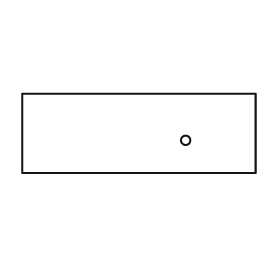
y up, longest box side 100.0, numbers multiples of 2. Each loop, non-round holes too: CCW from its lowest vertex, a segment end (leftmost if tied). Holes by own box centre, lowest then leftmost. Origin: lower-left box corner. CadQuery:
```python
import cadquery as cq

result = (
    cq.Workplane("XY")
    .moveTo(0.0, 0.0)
    .lineTo(100.0, 0.0)
    .lineTo(100.0, 34.0)
    .lineTo(0.0, 34.0)
    .close()
    .moveTo(70.0, 14.0)
    .circle(2.0)
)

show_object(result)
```